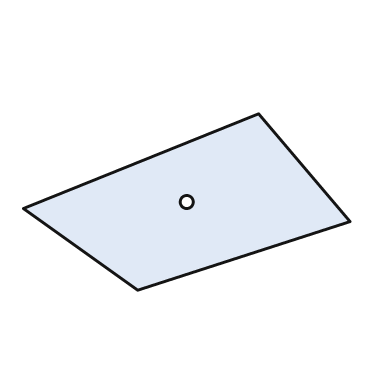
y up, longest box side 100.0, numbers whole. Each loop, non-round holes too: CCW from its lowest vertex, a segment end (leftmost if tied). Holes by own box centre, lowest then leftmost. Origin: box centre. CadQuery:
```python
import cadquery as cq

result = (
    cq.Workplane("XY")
    .moveTo(-15.0, -27.0)
    .lineTo(50.0, -6.0)
    .lineTo(22.0, 27.0)
    .lineTo(-50.0, -2.0)
    .close()
    .moveTo(0.0, 0.0)
    .circle(2.0)
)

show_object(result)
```